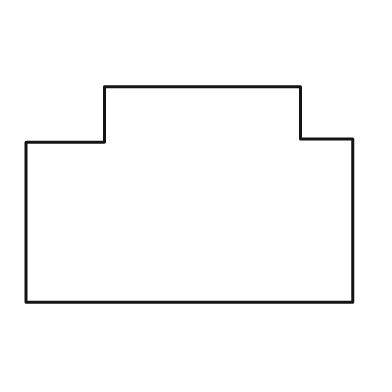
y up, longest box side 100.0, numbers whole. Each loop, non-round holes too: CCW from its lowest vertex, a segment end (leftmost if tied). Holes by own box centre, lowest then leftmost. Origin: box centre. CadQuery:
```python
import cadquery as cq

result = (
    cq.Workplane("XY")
    .moveTo(-50.0, -33.0)
    .lineTo(50.0, -33.0)
    .lineTo(50.0, 17.0)
    .lineTo(34.0, 17.0)
    .lineTo(34.0, 33.0)
    .lineTo(-26.0, 33.0)
    .lineTo(-26.0, 16.0)
    .lineTo(-50.0, 16.0)
    .close()
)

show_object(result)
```